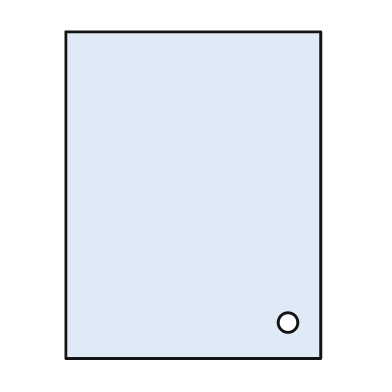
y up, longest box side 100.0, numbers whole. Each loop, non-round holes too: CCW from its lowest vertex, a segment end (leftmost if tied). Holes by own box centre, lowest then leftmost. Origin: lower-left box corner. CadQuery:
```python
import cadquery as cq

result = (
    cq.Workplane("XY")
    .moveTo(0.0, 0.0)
    .lineTo(78.0, 0.0)
    .lineTo(78.0, 100.0)
    .lineTo(0.0, 100.0)
    .close()
    .moveTo(68.0, 11.0)
    .circle(3.0)
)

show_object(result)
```